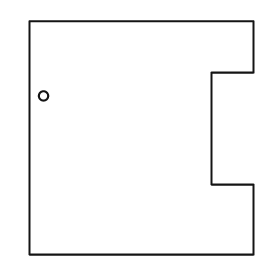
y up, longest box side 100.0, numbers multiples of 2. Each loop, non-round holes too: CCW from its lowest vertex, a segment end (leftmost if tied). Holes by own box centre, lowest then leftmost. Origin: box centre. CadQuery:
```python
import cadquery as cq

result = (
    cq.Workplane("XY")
    .moveTo(-48.0, -50.0)
    .lineTo(48.0, -50.0)
    .lineTo(48.0, -20.0)
    .lineTo(30.0, -20.0)
    .lineTo(30.0, 28.0)
    .lineTo(48.0, 28.0)
    .lineTo(48.0, 50.0)
    .lineTo(-48.0, 50.0)
    .close()
    .moveTo(-42.0, 18.0)
    .circle(2.0)
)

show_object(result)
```